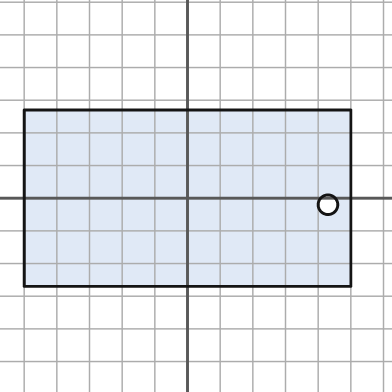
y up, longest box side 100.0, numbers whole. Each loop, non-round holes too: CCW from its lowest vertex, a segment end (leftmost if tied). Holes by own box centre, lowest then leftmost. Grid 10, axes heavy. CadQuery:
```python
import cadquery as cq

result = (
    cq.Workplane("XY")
    .moveTo(-50.0, -27.0)
    .lineTo(50.0, -27.0)
    .lineTo(50.0, 27.0)
    .lineTo(-50.0, 27.0)
    .close()
    .moveTo(43.0, -2.0)
    .circle(3.0)
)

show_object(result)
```